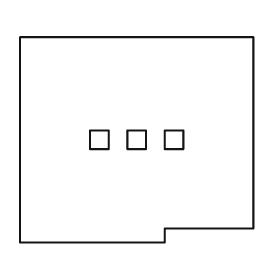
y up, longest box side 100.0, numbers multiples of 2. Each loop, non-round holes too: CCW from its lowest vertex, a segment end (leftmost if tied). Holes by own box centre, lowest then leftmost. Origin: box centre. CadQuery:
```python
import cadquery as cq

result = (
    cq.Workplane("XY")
    .moveTo(-50.0, -44.0)
    .lineTo(12.0, -44.0)
    .lineTo(12.0, -38.0)
    .lineTo(50.0, -38.0)
    .lineTo(50.0, 44.0)
    .lineTo(-50.0, 44.0)
    .close()
    .moveTo(-20.0, -4.0)
    .lineTo(-12.0, -4.0)
    .lineTo(-12.0, 4.0)
    .lineTo(-20.0, 4.0)
    .close()
    .moveTo(-4.0, -4.0)
    .lineTo(4.0, -4.0)
    .lineTo(4.0, 4.0)
    .lineTo(-4.0, 4.0)
    .close()
    .moveTo(12.0, -4.0)
    .lineTo(20.0, -4.0)
    .lineTo(20.0, 4.0)
    .lineTo(12.0, 4.0)
    .close()
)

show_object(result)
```